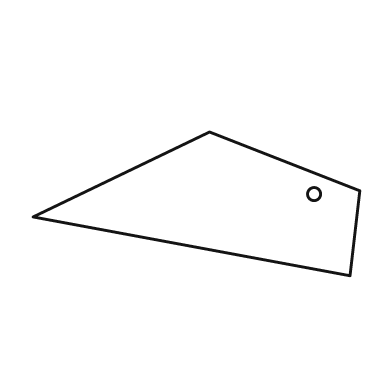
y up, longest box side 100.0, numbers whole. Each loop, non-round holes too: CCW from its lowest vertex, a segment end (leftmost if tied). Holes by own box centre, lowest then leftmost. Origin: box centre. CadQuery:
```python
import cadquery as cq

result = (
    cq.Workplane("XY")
    .moveTo(47.0, -22.0)
    .lineTo(50.0, 4.0)
    .lineTo(4.0, 22.0)
    .lineTo(-50.0, -4.0)
    .close()
    .moveTo(36.0, 3.0)
    .circle(2.0)
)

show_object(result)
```